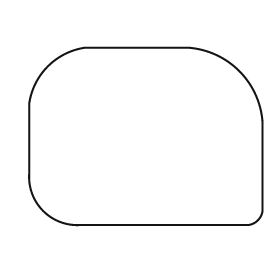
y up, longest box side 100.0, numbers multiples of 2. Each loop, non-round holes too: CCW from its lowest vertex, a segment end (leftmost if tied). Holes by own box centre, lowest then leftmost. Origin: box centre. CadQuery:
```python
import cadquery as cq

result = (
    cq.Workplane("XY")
    .moveTo(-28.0, -38.0)
    .lineTo(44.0, -38.0)
    .threePointArc((48.0, -36.0), (50.0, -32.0))
    .lineTo(50.0, 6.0)
    .threePointArc((40.0, 28.0), (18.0, 38.0))
    .lineTo(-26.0, 38.0)
    .threePointArc((-42.0, 30.0), (-50.0, 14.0))
    .lineTo(-50.0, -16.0)
    .threePointArc((-44.0, -32.0), (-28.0, -38.0))
    .close()
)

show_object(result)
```